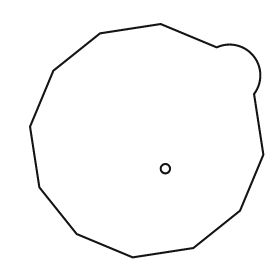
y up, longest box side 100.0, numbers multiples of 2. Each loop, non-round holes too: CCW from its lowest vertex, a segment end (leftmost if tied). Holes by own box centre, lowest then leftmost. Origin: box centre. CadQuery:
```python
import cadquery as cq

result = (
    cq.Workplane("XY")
    .moveTo(-6.0, -50.0)
    .lineTo(20.0, -46.0)
    .lineTo(40.0, -30.0)
    .lineTo(50.0, -6.0)
    .lineTo(46.0, 20.0)
    .threePointArc((46.0, 36.0), (30.0, 40.0))
    .lineTo(6.0, 50.0)
    .lineTo(-20.0, 46.0)
    .lineTo(-40.0, 30.0)
    .lineTo(-50.0, 6.0)
    .lineTo(-46.0, -20.0)
    .lineTo(-30.0, -40.0)
    .close()
    .moveTo(8.0, -12.0)
    .circle(2.0)
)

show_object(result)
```